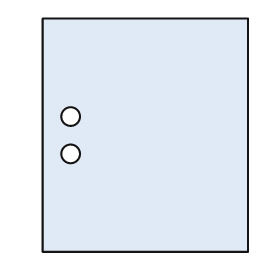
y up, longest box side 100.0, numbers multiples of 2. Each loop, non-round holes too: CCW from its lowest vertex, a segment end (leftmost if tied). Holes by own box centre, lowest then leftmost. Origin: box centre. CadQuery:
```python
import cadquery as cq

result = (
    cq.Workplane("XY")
    .moveTo(-44.0, -50.0)
    .lineTo(44.0, -50.0)
    .lineTo(44.0, 50.0)
    .lineTo(-44.0, 50.0)
    .close()
    .moveTo(-32.0, -8.0)
    .circle(4.0)
    .moveTo(-32.0, 8.0)
    .circle(4.0)
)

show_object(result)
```